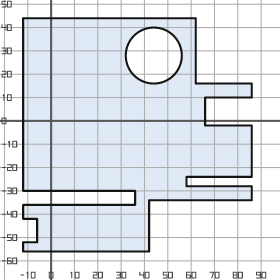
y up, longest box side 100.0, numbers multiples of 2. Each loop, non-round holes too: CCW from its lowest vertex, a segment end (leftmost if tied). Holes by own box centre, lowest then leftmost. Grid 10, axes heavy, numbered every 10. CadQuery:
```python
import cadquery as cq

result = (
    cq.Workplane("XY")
    .moveTo(-12.0, -56.0)
    .lineTo(42.0, -56.0)
    .lineTo(42.0, -34.0)
    .lineTo(86.0, -34.0)
    .lineTo(86.0, -28.0)
    .lineTo(58.0, -28.0)
    .lineTo(58.0, -24.0)
    .lineTo(86.0, -24.0)
    .lineTo(86.0, -2.0)
    .lineTo(66.0, -2.0)
    .lineTo(66.0, 10.0)
    .lineTo(86.0, 10.0)
    .lineTo(86.0, 16.0)
    .lineTo(62.0, 16.0)
    .lineTo(62.0, 44.0)
    .lineTo(-12.0, 44.0)
    .lineTo(-12.0, -30.0)
    .lineTo(36.0, -30.0)
    .lineTo(36.0, -36.0)
    .lineTo(-12.0, -36.0)
    .lineTo(-12.0, -42.0)
    .lineTo(-6.0, -42.0)
    .lineTo(-6.0, -52.0)
    .lineTo(-12.0, -52.0)
    .close()
    .moveTo(44.0, 28.0)
    .circle(12.0)
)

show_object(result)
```